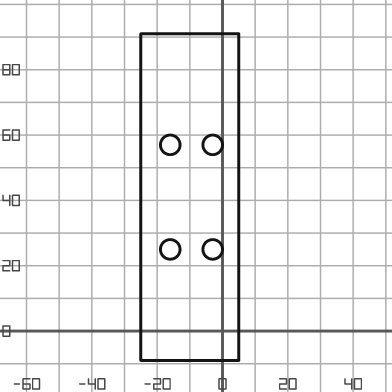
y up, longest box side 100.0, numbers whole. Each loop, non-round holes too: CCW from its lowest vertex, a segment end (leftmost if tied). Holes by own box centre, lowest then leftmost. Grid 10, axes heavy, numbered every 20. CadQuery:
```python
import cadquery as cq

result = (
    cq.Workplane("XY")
    .moveTo(-25.0, -9.0)
    .lineTo(5.0, -9.0)
    .lineTo(5.0, 91.0)
    .lineTo(-25.0, 91.0)
    .close()
    .moveTo(-16.0, 25.0)
    .circle(3.0)
    .moveTo(-3.0, 25.0)
    .circle(3.0)
    .moveTo(-16.0, 57.0)
    .circle(3.0)
    .moveTo(-3.0, 57.0)
    .circle(3.0)
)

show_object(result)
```